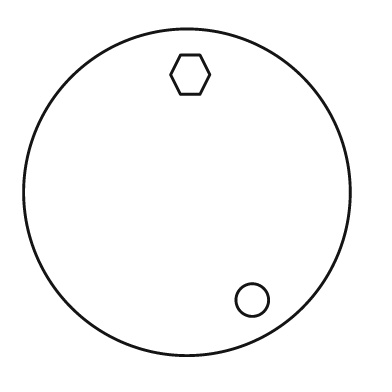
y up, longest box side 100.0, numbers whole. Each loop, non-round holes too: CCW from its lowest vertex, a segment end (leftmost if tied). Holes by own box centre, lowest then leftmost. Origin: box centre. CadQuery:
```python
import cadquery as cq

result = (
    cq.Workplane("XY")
    .moveTo(0.0, 0.0)
    .circle(50.0)
    .moveTo(20.0, -33.0)
    .circle(5.0)
    .moveTo(-2.0, 30.0)
    .lineTo(4.0, 30.0)
    .lineTo(7.0, 36.0)
    .lineTo(4.0, 42.0)
    .lineTo(-2.0, 42.0)
    .lineTo(-5.0, 36.0)
    .close()
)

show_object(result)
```